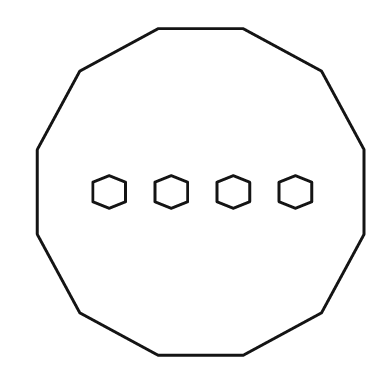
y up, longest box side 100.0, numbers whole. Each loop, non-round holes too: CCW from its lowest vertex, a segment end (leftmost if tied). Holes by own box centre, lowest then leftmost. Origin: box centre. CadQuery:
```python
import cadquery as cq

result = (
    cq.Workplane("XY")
    .moveTo(-13.0, -50.0)
    .lineTo(13.0, -50.0)
    .lineTo(37.0, -37.0)
    .lineTo(50.0, -13.0)
    .lineTo(50.0, 13.0)
    .lineTo(37.0, 37.0)
    .lineTo(13.0, 50.0)
    .lineTo(-13.0, 50.0)
    .lineTo(-37.0, 37.0)
    .lineTo(-50.0, 13.0)
    .lineTo(-50.0, -13.0)
    .lineTo(-37.0, -37.0)
    .close()
    .moveTo(-28.0, -5.0)
    .lineTo(-23.0, -3.0)
    .lineTo(-23.0, 3.0)
    .lineTo(-28.0, 5.0)
    .lineTo(-33.0, 3.0)
    .lineTo(-33.0, -3.0)
    .close()
    .moveTo(-9.0, -5.0)
    .lineTo(-4.0, -3.0)
    .lineTo(-4.0, 3.0)
    .lineTo(-9.0, 5.0)
    .lineTo(-14.0, 3.0)
    .lineTo(-14.0, -3.0)
    .close()
    .moveTo(10.0, -5.0)
    .lineTo(15.0, -3.0)
    .lineTo(15.0, 3.0)
    .lineTo(10.0, 5.0)
    .lineTo(5.0, 3.0)
    .lineTo(5.0, -3.0)
    .close()
    .moveTo(29.0, -5.0)
    .lineTo(34.0, -3.0)
    .lineTo(34.0, 3.0)
    .lineTo(29.0, 5.0)
    .lineTo(24.0, 3.0)
    .lineTo(24.0, -3.0)
    .close()
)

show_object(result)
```